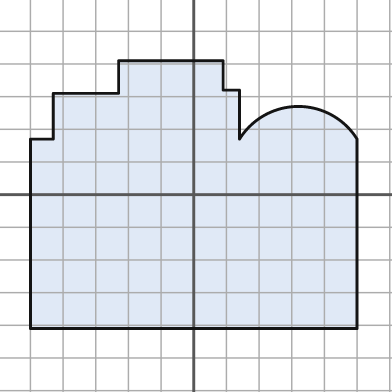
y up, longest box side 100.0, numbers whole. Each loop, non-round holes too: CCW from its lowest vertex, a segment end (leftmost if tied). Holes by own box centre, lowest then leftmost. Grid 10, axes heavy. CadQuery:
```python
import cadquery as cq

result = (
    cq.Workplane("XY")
    .moveTo(-50.0, -41.0)
    .lineTo(50.0, -41.0)
    .lineTo(50.0, 17.0)
    .threePointArc((32.0, 27.0), (14.0, 17.0))
    .lineTo(14.0, 32.0)
    .lineTo(9.0, 32.0)
    .lineTo(9.0, 41.0)
    .lineTo(-23.0, 41.0)
    .lineTo(-23.0, 31.0)
    .lineTo(-43.0, 31.0)
    .lineTo(-43.0, 17.0)
    .lineTo(-50.0, 17.0)
    .close()
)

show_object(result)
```